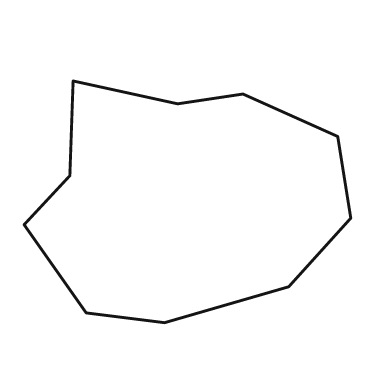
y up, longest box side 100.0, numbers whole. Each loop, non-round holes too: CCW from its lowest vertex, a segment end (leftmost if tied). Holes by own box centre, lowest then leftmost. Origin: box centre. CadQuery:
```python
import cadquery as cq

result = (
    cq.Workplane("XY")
    .moveTo(-7.0, -37.0)
    .lineTo(31.0, -26.0)
    .lineTo(50.0, -5.0)
    .lineTo(46.0, 20.0)
    .lineTo(17.0, 33.0)
    .lineTo(-3.0, 30.0)
    .lineTo(-35.0, 37.0)
    .lineTo(-36.0, 8.0)
    .lineTo(-50.0, -7.0)
    .lineTo(-31.0, -34.0)
    .close()
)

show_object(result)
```